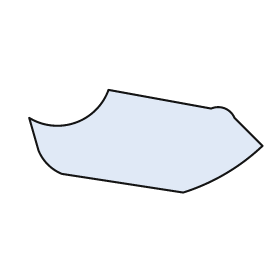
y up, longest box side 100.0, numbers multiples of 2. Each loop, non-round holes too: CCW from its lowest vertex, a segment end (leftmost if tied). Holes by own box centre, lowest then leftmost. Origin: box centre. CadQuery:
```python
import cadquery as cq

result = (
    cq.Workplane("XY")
    .moveTo(16.0, -22.0)
    .threePointArc((34.0, -14.0), (50.0, -2.0))
    .lineTo(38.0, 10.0)
    .threePointArc((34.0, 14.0), (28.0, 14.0))
    .lineTo(-16.0, 22.0)
    .threePointArc((-30.0, 8.0), (-50.0, 10.0))
    .lineTo(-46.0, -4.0)
    .threePointArc((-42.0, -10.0), (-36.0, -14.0))
    .close()
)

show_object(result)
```